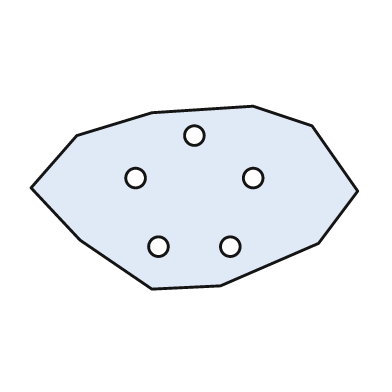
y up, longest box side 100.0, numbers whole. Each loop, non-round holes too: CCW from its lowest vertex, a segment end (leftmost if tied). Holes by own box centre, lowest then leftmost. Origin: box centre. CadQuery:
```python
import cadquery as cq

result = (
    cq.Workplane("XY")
    .moveTo(-13.0, -28.0)
    .lineTo(8.0, -27.0)
    .lineTo(38.0, -14.0)
    .lineTo(50.0, 2.0)
    .lineTo(36.0, 22.0)
    .lineTo(18.0, 28.0)
    .lineTo(-13.0, 26.0)
    .lineTo(-36.0, 19.0)
    .lineTo(-50.0, 3.0)
    .lineTo(-35.0, -13.0)
    .close()
    .moveTo(-11.0, -15.0)
    .circle(3.0)
    .moveTo(11.0, -15.0)
    .circle(3.0)
    .moveTo(-18.0, 6.0)
    .circle(3.0)
    .moveTo(18.0, 6.0)
    .circle(3.0)
    .moveTo(0.0, 19.0)
    .circle(3.0)
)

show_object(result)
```